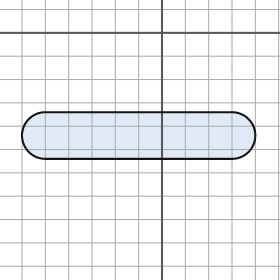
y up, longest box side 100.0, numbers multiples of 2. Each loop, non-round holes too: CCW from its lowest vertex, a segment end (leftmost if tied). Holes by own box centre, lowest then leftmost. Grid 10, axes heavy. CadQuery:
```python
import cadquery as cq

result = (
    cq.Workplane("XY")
    .moveTo(-50.0, -54.0)
    .lineTo(30.0, -54.0)
    .threePointArc((40.0, -44.0), (30.0, -34.0))
    .lineTo(-50.0, -34.0)
    .threePointArc((-60.0, -44.0), (-50.0, -54.0))
    .close()
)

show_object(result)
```